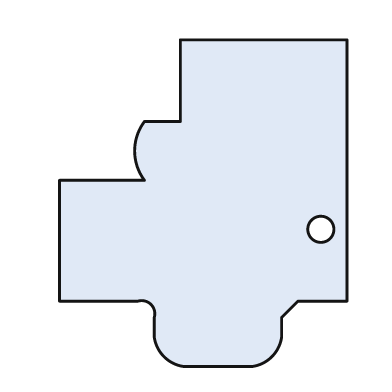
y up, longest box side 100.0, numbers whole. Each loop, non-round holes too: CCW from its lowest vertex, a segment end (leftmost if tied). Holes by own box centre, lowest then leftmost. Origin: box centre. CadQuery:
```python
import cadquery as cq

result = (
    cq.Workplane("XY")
    .moveTo(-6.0, -50.0)
    .lineTo(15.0, -50.0)
    .threePointArc((21.0, -47.0), (24.0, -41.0))
    .lineTo(24.0, -35.0)
    .lineTo(29.0, -30.0)
    .lineTo(44.0, -30.0)
    .lineTo(44.0, 50.0)
    .lineTo(-7.0, 50.0)
    .lineTo(-7.0, 25.0)
    .lineTo(-18.0, 25.0)
    .threePointArc((-21.0, 16.0), (-18.0, 7.0))
    .lineTo(-44.0, 7.0)
    .lineTo(-44.0, -30.0)
    .lineTo(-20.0, -30.0)
    .threePointArc((-16.0, -31.0), (-15.0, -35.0))
    .lineTo(-15.0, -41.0)
    .threePointArc((-12.0, -47.0), (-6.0, -50.0))
    .close()
    .moveTo(36.0, -8.0)
    .circle(4.0)
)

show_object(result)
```